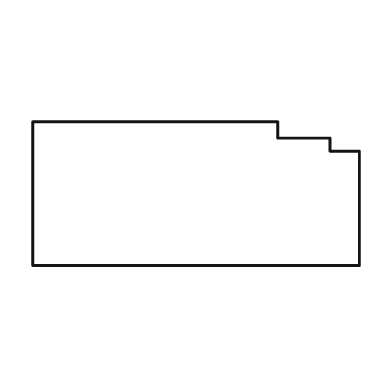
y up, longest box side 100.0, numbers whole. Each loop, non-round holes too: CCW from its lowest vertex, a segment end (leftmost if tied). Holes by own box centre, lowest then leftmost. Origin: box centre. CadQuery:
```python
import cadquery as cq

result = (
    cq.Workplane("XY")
    .moveTo(-50.0, -22.0)
    .lineTo(50.0, -22.0)
    .lineTo(50.0, 13.0)
    .lineTo(41.0, 13.0)
    .lineTo(41.0, 17.0)
    .lineTo(25.0, 17.0)
    .lineTo(25.0, 22.0)
    .lineTo(-50.0, 22.0)
    .close()
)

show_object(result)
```